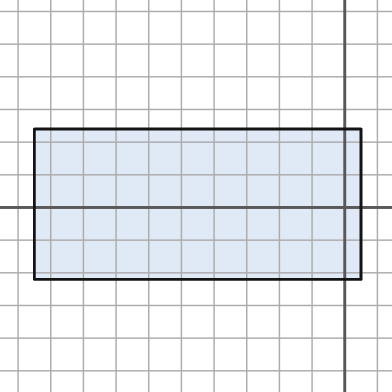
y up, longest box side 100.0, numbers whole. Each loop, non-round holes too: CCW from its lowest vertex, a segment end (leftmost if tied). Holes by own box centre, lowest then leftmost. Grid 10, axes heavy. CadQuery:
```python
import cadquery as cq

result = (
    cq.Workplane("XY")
    .moveTo(-95.0, -22.0)
    .lineTo(5.0, -22.0)
    .lineTo(5.0, 24.0)
    .lineTo(-95.0, 24.0)
    .close()
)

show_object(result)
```